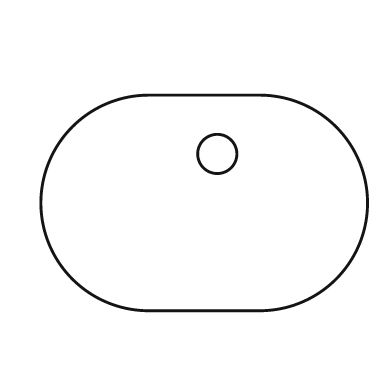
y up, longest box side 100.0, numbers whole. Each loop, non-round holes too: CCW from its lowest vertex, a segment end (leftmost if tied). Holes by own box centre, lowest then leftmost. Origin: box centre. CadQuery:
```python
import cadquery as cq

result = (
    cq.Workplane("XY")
    .moveTo(-17.0, -33.0)
    .lineTo(17.0, -33.0)
    .threePointArc((50.0, 0.0), (17.0, 33.0))
    .lineTo(-17.0, 33.0)
    .threePointArc((-50.0, 0.0), (-17.0, -33.0))
    .close()
    .moveTo(4.0, 15.0)
    .circle(6.0)
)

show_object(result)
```